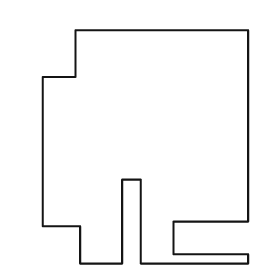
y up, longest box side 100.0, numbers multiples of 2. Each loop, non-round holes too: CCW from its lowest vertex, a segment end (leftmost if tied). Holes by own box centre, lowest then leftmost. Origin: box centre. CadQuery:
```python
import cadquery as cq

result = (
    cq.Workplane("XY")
    .moveTo(-28.0, -50.0)
    .lineTo(-10.0, -50.0)
    .lineTo(-10.0, -14.0)
    .lineTo(-2.0, -14.0)
    .lineTo(-2.0, -50.0)
    .lineTo(44.0, -50.0)
    .lineTo(44.0, -46.0)
    .lineTo(12.0, -46.0)
    .lineTo(12.0, -32.0)
    .lineTo(44.0, -32.0)
    .lineTo(44.0, 50.0)
    .lineTo(-30.0, 50.0)
    .lineTo(-30.0, 30.0)
    .lineTo(-44.0, 30.0)
    .lineTo(-44.0, -34.0)
    .lineTo(-28.0, -34.0)
    .close()
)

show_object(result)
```